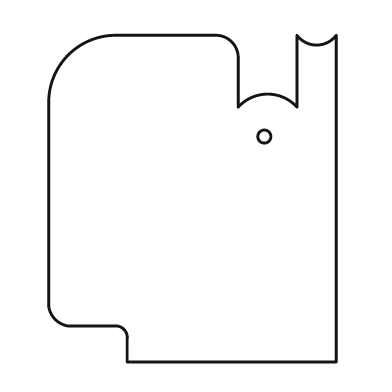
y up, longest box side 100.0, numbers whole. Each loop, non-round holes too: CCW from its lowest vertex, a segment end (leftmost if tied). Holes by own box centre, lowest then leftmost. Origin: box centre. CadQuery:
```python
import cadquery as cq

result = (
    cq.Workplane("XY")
    .moveTo(-20.0, -50.0)
    .lineTo(44.0, -50.0)
    .lineTo(44.0, 50.0)
    .threePointArc((38.0, 47.0), (32.0, 50.0))
    .lineTo(32.0, 28.0)
    .threePointArc((23.0, 32.0), (14.0, 28.0))
    .lineTo(14.0, 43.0)
    .threePointArc((12.0, 48.0), (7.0, 50.0))
    .lineTo(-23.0, 50.0)
    .threePointArc((-38.0, 44.0), (-44.0, 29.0))
    .lineTo(-44.0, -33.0)
    .threePointArc((-42.0, -37.0), (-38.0, -39.0))
    .lineTo(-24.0, -39.0)
    .threePointArc((-21.0, -40.0), (-20.0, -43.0))
    .close()
    .moveTo(22.0, 19.0)
    .circle(2.0)
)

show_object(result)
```